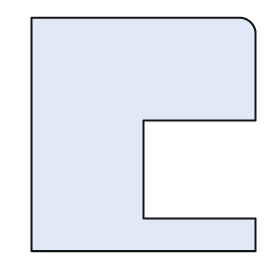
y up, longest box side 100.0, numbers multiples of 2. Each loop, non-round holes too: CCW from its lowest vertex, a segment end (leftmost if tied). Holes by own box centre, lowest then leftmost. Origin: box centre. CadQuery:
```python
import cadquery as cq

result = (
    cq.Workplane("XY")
    .moveTo(-48.0, -50.0)
    .lineTo(48.0, -50.0)
    .lineTo(48.0, -36.0)
    .lineTo(0.0, -36.0)
    .lineTo(0.0, 6.0)
    .lineTo(48.0, 6.0)
    .lineTo(48.0, 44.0)
    .threePointArc((46.0, 48.0), (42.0, 50.0))
    .lineTo(-48.0, 50.0)
    .close()
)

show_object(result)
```